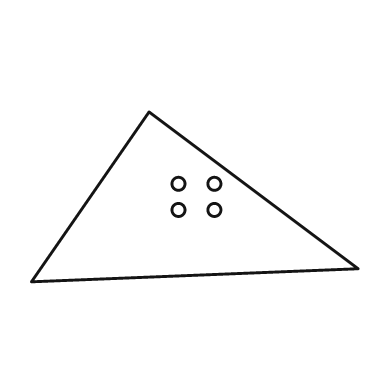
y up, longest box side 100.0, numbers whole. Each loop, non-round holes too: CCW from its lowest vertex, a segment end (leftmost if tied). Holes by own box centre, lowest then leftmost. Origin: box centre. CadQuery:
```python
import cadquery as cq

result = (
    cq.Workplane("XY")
    .moveTo(-50.0, -26.0)
    .lineTo(50.0, -22.0)
    .lineTo(-14.0, 26.0)
    .close()
    .moveTo(-5.0, -4.0)
    .circle(2.0)
    .moveTo(6.0, -4.0)
    .circle(2.0)
    .moveTo(-5.0, 4.0)
    .circle(2.0)
    .moveTo(6.0, 4.0)
    .circle(2.0)
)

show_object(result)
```